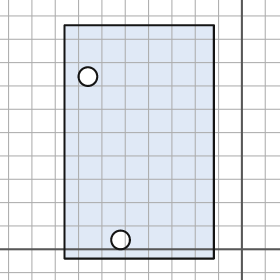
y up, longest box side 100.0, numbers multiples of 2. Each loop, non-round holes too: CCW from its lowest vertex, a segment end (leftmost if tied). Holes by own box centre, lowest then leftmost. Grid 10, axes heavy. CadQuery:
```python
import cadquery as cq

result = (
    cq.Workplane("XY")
    .moveTo(-76.0, -4.0)
    .lineTo(-12.0, -4.0)
    .lineTo(-12.0, 96.0)
    .lineTo(-76.0, 96.0)
    .close()
    .moveTo(-52.0, 4.0)
    .circle(4.0)
    .moveTo(-66.0, 74.0)
    .circle(4.0)
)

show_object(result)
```